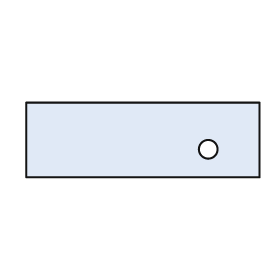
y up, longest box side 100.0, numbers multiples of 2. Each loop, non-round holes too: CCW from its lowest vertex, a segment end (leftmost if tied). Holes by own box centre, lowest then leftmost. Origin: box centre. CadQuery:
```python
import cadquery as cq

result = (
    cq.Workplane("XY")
    .moveTo(-50.0, -16.0)
    .lineTo(50.0, -16.0)
    .lineTo(50.0, 16.0)
    .lineTo(-50.0, 16.0)
    .close()
    .moveTo(28.0, -4.0)
    .circle(4.0)
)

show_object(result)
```